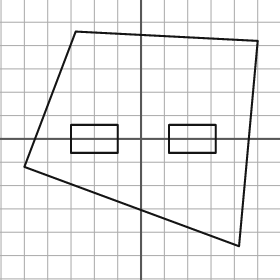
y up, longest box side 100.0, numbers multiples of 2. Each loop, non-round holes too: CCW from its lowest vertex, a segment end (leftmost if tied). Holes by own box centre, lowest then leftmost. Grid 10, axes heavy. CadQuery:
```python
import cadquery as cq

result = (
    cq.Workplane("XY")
    .moveTo(42.0, -46.0)
    .lineTo(50.0, 42.0)
    .lineTo(-28.0, 46.0)
    .lineTo(-50.0, -12.0)
    .close()
    .moveTo(-30.0, -6.0)
    .lineTo(-10.0, -6.0)
    .lineTo(-10.0, 6.0)
    .lineTo(-30.0, 6.0)
    .close()
    .moveTo(12.0, -6.0)
    .lineTo(32.0, -6.0)
    .lineTo(32.0, 6.0)
    .lineTo(12.0, 6.0)
    .close()
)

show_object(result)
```